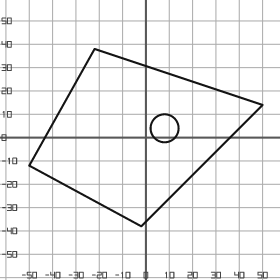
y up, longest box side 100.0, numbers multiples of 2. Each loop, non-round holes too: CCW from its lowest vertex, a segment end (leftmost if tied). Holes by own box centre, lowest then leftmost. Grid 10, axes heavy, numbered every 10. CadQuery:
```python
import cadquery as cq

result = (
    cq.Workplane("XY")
    .moveTo(-2.0, -38.0)
    .lineTo(50.0, 14.0)
    .lineTo(-22.0, 38.0)
    .lineTo(-50.0, -12.0)
    .close()
    .moveTo(8.0, 4.0)
    .circle(6.0)
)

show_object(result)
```